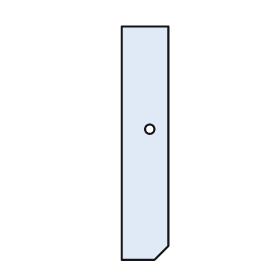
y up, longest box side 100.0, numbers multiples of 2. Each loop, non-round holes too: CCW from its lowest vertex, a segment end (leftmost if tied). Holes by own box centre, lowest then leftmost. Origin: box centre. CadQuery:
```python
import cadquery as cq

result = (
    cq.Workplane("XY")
    .moveTo(-10.0, -50.0)
    .lineTo(4.0, -50.0)
    .lineTo(10.0, -44.0)
    .lineTo(10.0, 50.0)
    .lineTo(-10.0, 50.0)
    .close()
    .moveTo(2.0, 6.0)
    .circle(2.0)
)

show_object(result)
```